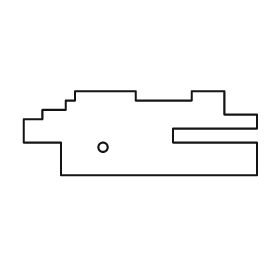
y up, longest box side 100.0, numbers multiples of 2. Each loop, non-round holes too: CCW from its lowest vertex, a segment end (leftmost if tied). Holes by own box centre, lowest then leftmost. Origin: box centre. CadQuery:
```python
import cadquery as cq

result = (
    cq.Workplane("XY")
    .moveTo(-34.0, -18.0)
    .lineTo(50.0, -18.0)
    .lineTo(50.0, -4.0)
    .lineTo(14.0, -4.0)
    .lineTo(14.0, 2.0)
    .lineTo(50.0, 2.0)
    .lineTo(50.0, 8.0)
    .lineTo(36.0, 8.0)
    .lineTo(36.0, 18.0)
    .lineTo(22.0, 18.0)
    .lineTo(22.0, 14.0)
    .lineTo(-2.0, 14.0)
    .lineTo(-2.0, 18.0)
    .lineTo(-28.0, 18.0)
    .lineTo(-28.0, 14.0)
    .lineTo(-32.0, 14.0)
    .lineTo(-32.0, 10.0)
    .lineTo(-42.0, 10.0)
    .lineTo(-42.0, 6.0)
    .lineTo(-50.0, 6.0)
    .lineTo(-50.0, -4.0)
    .lineTo(-34.0, -4.0)
    .close()
    .moveTo(-16.0, -6.0)
    .circle(2.0)
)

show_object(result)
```